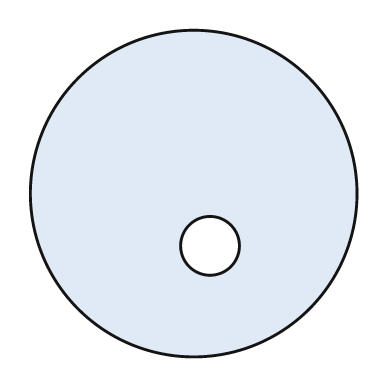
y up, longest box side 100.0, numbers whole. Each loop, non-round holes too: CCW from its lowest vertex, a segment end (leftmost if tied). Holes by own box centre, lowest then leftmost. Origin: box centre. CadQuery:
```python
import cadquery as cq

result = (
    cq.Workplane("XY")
    .moveTo(0.0, 0.0)
    .circle(50.0)
    .moveTo(5.0, -16.0)
    .circle(9.0)
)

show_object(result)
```